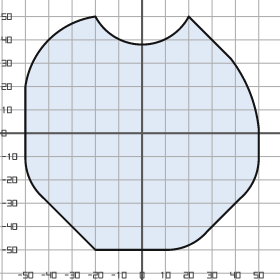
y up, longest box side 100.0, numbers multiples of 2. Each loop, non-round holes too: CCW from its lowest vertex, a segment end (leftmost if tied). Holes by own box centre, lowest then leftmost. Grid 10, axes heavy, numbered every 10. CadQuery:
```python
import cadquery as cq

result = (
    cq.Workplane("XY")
    .moveTo(-20.0, -50.0)
    .lineTo(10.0, -50.0)
    .threePointArc((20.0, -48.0), (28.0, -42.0))
    .lineTo(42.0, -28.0)
    .threePointArc((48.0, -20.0), (50.0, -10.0))
    .lineTo(50.0, 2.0)
    .threePointArc((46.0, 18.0), (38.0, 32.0))
    .lineTo(20.0, 50.0)
    .threePointArc((0.0, 38.0), (-20.0, 50.0))
    .threePointArc((-40.0, 40.0), (-50.0, 20.0))
    .lineTo(-50.0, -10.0)
    .threePointArc((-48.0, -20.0), (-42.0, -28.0))
    .close()
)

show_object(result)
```